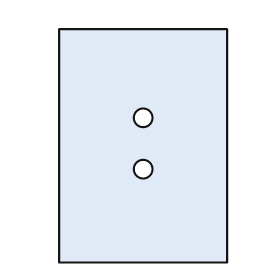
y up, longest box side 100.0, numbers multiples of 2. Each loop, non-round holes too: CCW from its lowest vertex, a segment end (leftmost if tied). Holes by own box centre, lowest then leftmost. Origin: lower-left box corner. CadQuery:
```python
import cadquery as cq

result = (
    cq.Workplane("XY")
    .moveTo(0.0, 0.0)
    .lineTo(72.0, 0.0)
    .lineTo(72.0, 100.0)
    .lineTo(0.0, 100.0)
    .close()
    .moveTo(36.0, 40.0)
    .circle(4.0)
    .moveTo(36.0, 62.0)
    .circle(4.0)
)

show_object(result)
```